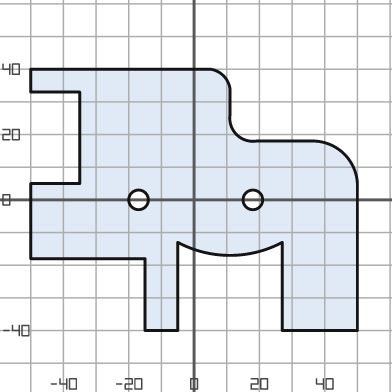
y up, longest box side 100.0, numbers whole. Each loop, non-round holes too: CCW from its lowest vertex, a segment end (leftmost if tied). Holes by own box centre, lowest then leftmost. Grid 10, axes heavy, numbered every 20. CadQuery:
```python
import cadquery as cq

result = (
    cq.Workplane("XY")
    .moveTo(-15.0, -40.0)
    .lineTo(-5.0, -40.0)
    .lineTo(-5.0, -13.0)
    .threePointArc((11.0, -17.0), (27.0, -13.0))
    .lineTo(27.0, -40.0)
    .lineTo(50.0, -40.0)
    .lineTo(50.0, 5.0)
    .threePointArc((46.0, 14.0), (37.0, 18.0))
    .lineTo(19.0, 18.0)
    .threePointArc((13.0, 20.0), (11.0, 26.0))
    .lineTo(11.0, 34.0)
    .threePointArc((9.0, 38.0), (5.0, 40.0))
    .lineTo(-50.0, 40.0)
    .lineTo(-50.0, 33.0)
    .lineTo(-35.0, 33.0)
    .lineTo(-35.0, 5.0)
    .lineTo(-50.0, 5.0)
    .lineTo(-50.0, -18.0)
    .lineTo(-15.0, -18.0)
    .close()
    .moveTo(-17.0, 0.0)
    .circle(3.0)
    .moveTo(18.0, 0.0)
    .circle(3.0)
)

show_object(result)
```